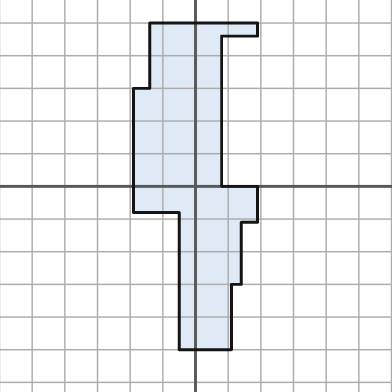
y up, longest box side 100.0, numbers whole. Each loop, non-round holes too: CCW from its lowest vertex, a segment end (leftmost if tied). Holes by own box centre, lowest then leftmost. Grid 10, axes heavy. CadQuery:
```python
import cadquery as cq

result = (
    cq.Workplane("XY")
    .moveTo(-5.0, -50.0)
    .lineTo(11.0, -50.0)
    .lineTo(11.0, -30.0)
    .lineTo(14.0, -30.0)
    .lineTo(14.0, -11.0)
    .lineTo(19.0, -11.0)
    .lineTo(19.0, 0.0)
    .lineTo(8.0, 0.0)
    .lineTo(8.0, 46.0)
    .lineTo(19.0, 46.0)
    .lineTo(19.0, 50.0)
    .lineTo(-14.0, 50.0)
    .lineTo(-14.0, 30.0)
    .lineTo(-19.0, 30.0)
    .lineTo(-19.0, -8.0)
    .lineTo(-5.0, -8.0)
    .close()
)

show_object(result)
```